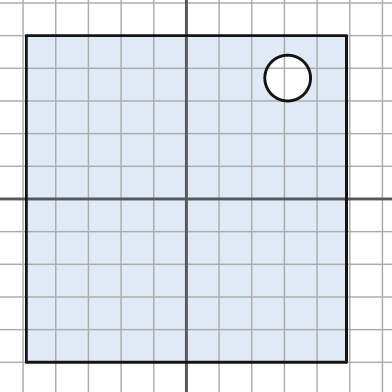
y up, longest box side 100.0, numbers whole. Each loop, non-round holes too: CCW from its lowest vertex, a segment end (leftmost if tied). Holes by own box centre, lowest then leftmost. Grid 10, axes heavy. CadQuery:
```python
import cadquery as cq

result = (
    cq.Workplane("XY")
    .moveTo(-49.0, -50.0)
    .lineTo(49.0, -50.0)
    .lineTo(49.0, 50.0)
    .lineTo(-49.0, 50.0)
    .close()
    .moveTo(31.0, 37.0)
    .circle(7.0)
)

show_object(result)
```